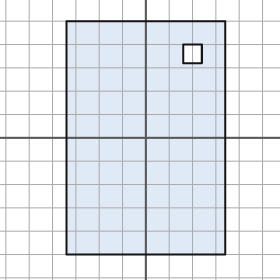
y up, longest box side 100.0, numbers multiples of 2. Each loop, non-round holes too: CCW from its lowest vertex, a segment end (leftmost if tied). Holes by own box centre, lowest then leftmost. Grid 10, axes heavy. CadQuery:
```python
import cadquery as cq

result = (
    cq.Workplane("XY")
    .moveTo(-34.0, -50.0)
    .lineTo(34.0, -50.0)
    .lineTo(34.0, 50.0)
    .lineTo(-34.0, 50.0)
    .close()
    .moveTo(16.0, 32.0)
    .lineTo(24.0, 32.0)
    .lineTo(24.0, 40.0)
    .lineTo(16.0, 40.0)
    .close()
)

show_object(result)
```